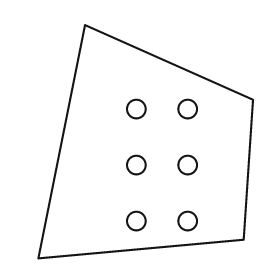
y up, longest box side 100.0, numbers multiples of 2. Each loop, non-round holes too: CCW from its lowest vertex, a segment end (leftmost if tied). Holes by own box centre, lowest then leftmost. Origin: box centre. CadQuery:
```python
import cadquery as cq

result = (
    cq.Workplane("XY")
    .moveTo(-46.0, -50.0)
    .lineTo(42.0, -42.0)
    .lineTo(46.0, 18.0)
    .lineTo(-26.0, 50.0)
    .close()
    .moveTo(-4.0, -34.0)
    .circle(4.0)
    .moveTo(18.0, -34.0)
    .circle(4.0)
    .moveTo(-4.0, -10.0)
    .circle(4.0)
    .moveTo(18.0, -10.0)
    .circle(4.0)
    .moveTo(-4.0, 14.0)
    .circle(4.0)
    .moveTo(18.0, 14.0)
    .circle(4.0)
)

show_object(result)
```